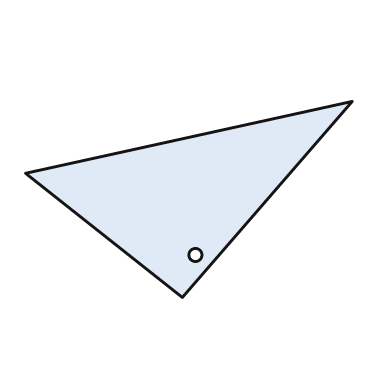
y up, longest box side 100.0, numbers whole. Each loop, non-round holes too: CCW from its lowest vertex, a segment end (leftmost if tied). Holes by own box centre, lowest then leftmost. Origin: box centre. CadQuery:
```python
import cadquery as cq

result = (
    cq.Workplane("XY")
    .moveTo(-2.0, -30.0)
    .lineTo(50.0, 30.0)
    .lineTo(-50.0, 8.0)
    .close()
    .moveTo(2.0, -17.0)
    .circle(2.0)
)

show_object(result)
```